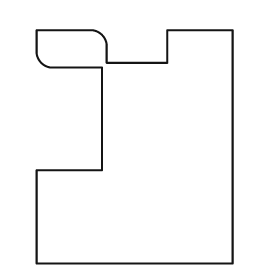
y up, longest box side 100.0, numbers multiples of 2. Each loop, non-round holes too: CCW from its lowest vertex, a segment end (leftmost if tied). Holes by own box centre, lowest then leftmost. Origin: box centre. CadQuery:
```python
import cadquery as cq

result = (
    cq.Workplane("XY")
    .moveTo(-42.0, -50.0)
    .lineTo(42.0, -50.0)
    .lineTo(42.0, 50.0)
    .lineTo(14.0, 50.0)
    .lineTo(14.0, 36.0)
    .lineTo(-12.0, 36.0)
    .lineTo(-12.0, 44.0)
    .threePointArc((-14.0, 48.0), (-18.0, 50.0))
    .lineTo(-42.0, 50.0)
    .lineTo(-42.0, 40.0)
    .threePointArc((-40.0, 36.0), (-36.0, 34.0))
    .lineTo(-14.0, 34.0)
    .lineTo(-14.0, -10.0)
    .lineTo(-42.0, -10.0)
    .close()
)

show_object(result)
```